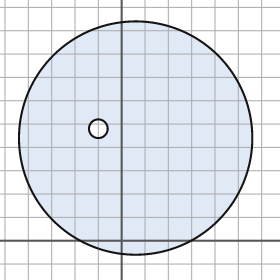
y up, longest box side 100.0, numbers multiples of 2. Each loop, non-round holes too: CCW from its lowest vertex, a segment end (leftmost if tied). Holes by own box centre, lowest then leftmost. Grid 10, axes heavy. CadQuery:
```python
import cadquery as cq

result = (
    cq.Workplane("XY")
    .moveTo(6.0, 44.0)
    .circle(50.0)
    .moveTo(-10.0, 48.0)
    .circle(4.0)
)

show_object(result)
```